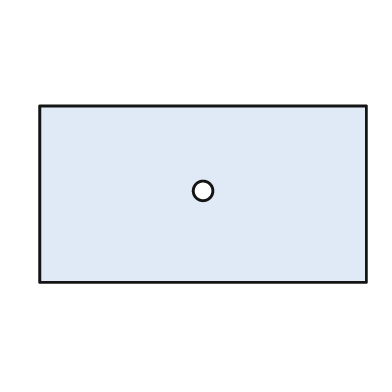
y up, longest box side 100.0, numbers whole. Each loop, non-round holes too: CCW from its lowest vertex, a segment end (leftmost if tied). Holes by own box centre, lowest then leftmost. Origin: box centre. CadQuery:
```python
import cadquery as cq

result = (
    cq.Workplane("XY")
    .moveTo(-50.0, -27.0)
    .lineTo(50.0, -27.0)
    .lineTo(50.0, 27.0)
    .lineTo(-50.0, 27.0)
    .close()
    .moveTo(0.0, 1.0)
    .circle(3.0)
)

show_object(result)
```